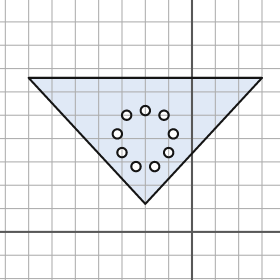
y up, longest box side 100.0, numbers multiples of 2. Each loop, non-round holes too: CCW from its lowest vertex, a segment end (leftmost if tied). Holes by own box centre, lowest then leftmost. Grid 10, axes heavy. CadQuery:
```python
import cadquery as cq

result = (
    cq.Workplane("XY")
    .moveTo(-20.0, 12.0)
    .lineTo(30.0, 66.0)
    .lineTo(-70.0, 66.0)
    .close()
    .moveTo(-24.0, 28.0)
    .circle(2.0)
    .moveTo(-16.0, 28.0)
    .circle(2.0)
    .moveTo(-30.0, 34.0)
    .circle(2.0)
    .moveTo(-10.0, 34.0)
    .circle(2.0)
    .moveTo(-32.0, 42.0)
    .circle(2.0)
    .moveTo(-8.0, 42.0)
    .circle(2.0)
    .moveTo(-28.0, 50.0)
    .circle(2.0)
    .moveTo(-12.0, 50.0)
    .circle(2.0)
    .moveTo(-20.0, 52.0)
    .circle(2.0)
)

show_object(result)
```